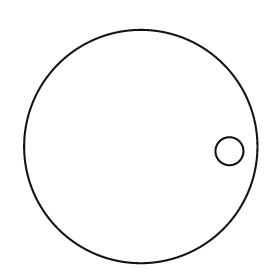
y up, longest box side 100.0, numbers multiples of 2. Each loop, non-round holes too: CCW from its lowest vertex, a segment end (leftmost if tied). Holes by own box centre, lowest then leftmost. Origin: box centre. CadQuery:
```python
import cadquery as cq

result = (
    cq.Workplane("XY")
    .moveTo(0.0, 0.0)
    .circle(50.0)
    .moveTo(38.0, -2.0)
    .circle(6.0)
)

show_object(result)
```